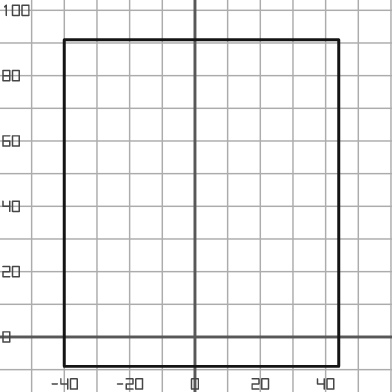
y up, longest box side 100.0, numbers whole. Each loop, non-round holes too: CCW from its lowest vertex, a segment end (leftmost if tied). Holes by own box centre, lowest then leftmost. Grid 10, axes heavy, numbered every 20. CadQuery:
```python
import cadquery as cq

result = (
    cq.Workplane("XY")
    .moveTo(-40.0, -9.0)
    .lineTo(44.0, -9.0)
    .lineTo(44.0, 91.0)
    .lineTo(-40.0, 91.0)
    .close()
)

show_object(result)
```